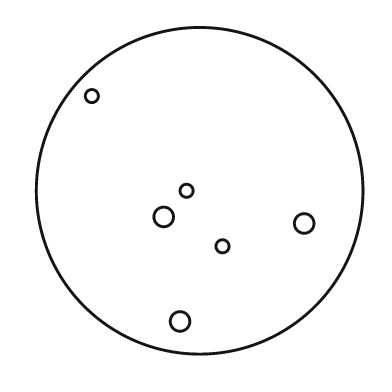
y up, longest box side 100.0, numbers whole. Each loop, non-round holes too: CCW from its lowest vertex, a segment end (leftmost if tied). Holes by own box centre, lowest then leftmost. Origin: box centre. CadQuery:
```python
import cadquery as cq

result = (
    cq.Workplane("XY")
    .moveTo(0.0, 0.0)
    .circle(50.0)
    .moveTo(-6.0, -40.0)
    .circle(3.0)
    .moveTo(7.0, -17.0)
    .circle(2.0)
    .moveTo(32.0, -10.0)
    .circle(3.0)
    .moveTo(-11.0, -8.0)
    .circle(3.0)
    .moveTo(-4.0, 0.0)
    .circle(2.0)
    .moveTo(-33.0, 29.0)
    .circle(2.0)
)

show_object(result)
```